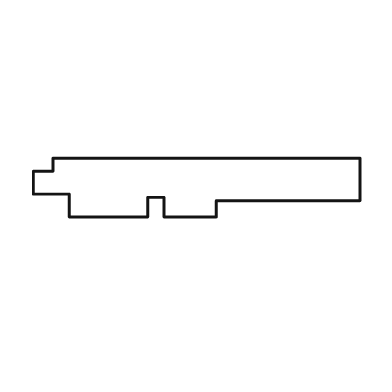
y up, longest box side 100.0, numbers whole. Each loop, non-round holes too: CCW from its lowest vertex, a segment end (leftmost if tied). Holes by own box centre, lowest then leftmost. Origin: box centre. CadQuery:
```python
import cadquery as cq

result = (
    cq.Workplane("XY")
    .moveTo(-39.0, -9.0)
    .lineTo(-15.0, -9.0)
    .lineTo(-15.0, -3.0)
    .lineTo(-10.0, -3.0)
    .lineTo(-10.0, -9.0)
    .lineTo(6.0, -9.0)
    .lineTo(6.0, -4.0)
    .lineTo(50.0, -4.0)
    .lineTo(50.0, 9.0)
    .lineTo(-44.0, 9.0)
    .lineTo(-44.0, 5.0)
    .lineTo(-50.0, 5.0)
    .lineTo(-50.0, -2.0)
    .lineTo(-39.0, -2.0)
    .close()
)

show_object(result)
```